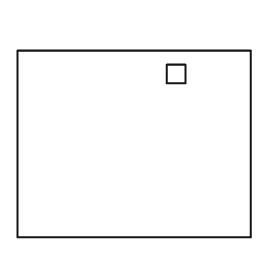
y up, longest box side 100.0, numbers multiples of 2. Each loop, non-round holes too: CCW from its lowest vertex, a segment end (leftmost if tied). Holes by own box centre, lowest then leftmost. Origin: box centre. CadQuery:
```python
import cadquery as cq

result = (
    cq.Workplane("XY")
    .moveTo(-50.0, -40.0)
    .lineTo(50.0, -40.0)
    .lineTo(50.0, 40.0)
    .lineTo(-50.0, 40.0)
    .close()
    .moveTo(14.0, 26.0)
    .lineTo(22.0, 26.0)
    .lineTo(22.0, 34.0)
    .lineTo(14.0, 34.0)
    .close()
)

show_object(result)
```